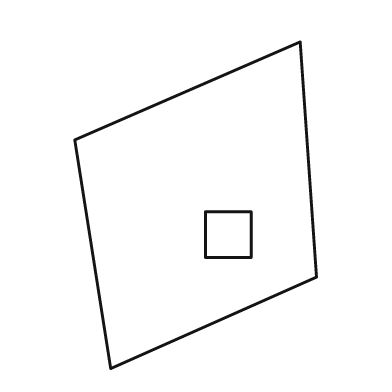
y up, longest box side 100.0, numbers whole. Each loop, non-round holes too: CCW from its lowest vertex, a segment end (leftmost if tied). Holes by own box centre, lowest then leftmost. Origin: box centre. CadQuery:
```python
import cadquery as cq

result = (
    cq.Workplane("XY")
    .moveTo(-26.0, -50.0)
    .lineTo(37.0, -22.0)
    .lineTo(32.0, 50.0)
    .lineTo(-37.0, 20.0)
    .close()
    .moveTo(3.0, -16.0)
    .lineTo(17.0, -16.0)
    .lineTo(17.0, -2.0)
    .lineTo(3.0, -2.0)
    .close()
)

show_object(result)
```